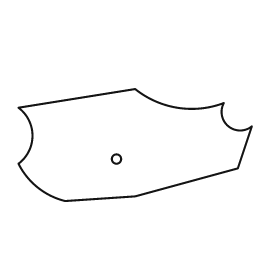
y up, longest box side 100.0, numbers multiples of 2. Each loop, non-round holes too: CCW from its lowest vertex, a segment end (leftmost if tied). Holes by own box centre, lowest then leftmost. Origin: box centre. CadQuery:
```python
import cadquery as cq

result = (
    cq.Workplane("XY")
    .moveTo(-30.0, -24.0)
    .lineTo(0.0, -22.0)
    .lineTo(44.0, -10.0)
    .lineTo(50.0, 8.0)
    .threePointArc((40.0, 8.0), (38.0, 18.0))
    .threePointArc((18.0, 16.0), (0.0, 24.0))
    .lineTo(-50.0, 16.0)
    .threePointArc((-44.0, 4.0), (-50.0, -8.0))
    .threePointArc((-42.0, -18.0), (-30.0, -24.0))
    .close()
    .moveTo(-8.0, -6.0)
    .circle(2.0)
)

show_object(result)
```